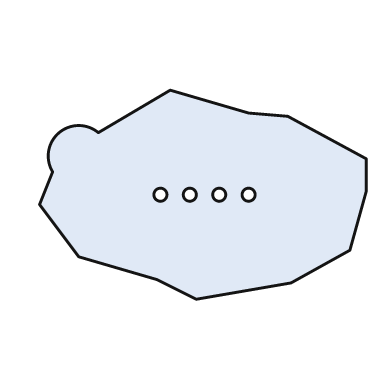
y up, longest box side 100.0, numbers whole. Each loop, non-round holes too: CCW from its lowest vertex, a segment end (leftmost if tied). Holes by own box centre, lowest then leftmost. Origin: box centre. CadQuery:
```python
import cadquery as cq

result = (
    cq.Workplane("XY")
    .moveTo(-2.0, -32.0)
    .lineTo(27.0, -27.0)
    .lineTo(45.0, -17.0)
    .lineTo(50.0, 1.0)
    .lineTo(50.0, 11.0)
    .lineTo(26.0, 24.0)
    .lineTo(14.0, 25.0)
    .lineTo(-10.0, 32.0)
    .lineTo(-32.0, 19.0)
    .threePointArc((-44.0, 19.0), (-46.0, 7.0))
    .lineTo(-50.0, -3.0)
    .lineTo(-38.0, -19.0)
    .lineTo(-14.0, -26.0)
    .close()
    .moveTo(-13.0, 0.0)
    .circle(2.0)
    .moveTo(-4.0, 0.0)
    .circle(2.0)
    .moveTo(5.0, 0.0)
    .circle(2.0)
    .moveTo(14.0, 0.0)
    .circle(2.0)
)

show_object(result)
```